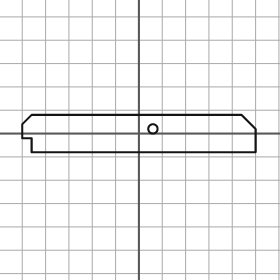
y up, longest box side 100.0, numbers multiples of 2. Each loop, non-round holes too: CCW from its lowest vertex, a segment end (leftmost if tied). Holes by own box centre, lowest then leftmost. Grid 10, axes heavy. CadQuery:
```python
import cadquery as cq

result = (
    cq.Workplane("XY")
    .moveTo(-46.0, -8.0)
    .lineTo(50.0, -8.0)
    .lineTo(50.0, 2.0)
    .lineTo(44.0, 8.0)
    .lineTo(-46.0, 8.0)
    .lineTo(-50.0, 4.0)
    .lineTo(-50.0, -2.0)
    .lineTo(-46.0, -2.0)
    .close()
    .moveTo(6.0, 2.0)
    .circle(2.0)
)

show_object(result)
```